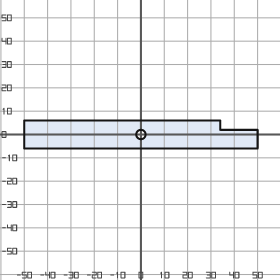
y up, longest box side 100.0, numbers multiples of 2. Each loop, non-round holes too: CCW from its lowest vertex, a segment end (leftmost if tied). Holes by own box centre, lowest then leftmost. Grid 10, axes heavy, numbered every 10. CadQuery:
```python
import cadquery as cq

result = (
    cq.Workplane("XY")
    .moveTo(-50.0, -6.0)
    .lineTo(50.0, -6.0)
    .lineTo(50.0, 2.0)
    .lineTo(34.0, 2.0)
    .lineTo(34.0, 6.0)
    .lineTo(-50.0, 6.0)
    .close()
    .moveTo(0.0, 0.0)
    .circle(2.0)
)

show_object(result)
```